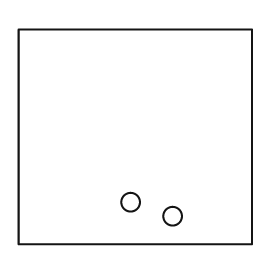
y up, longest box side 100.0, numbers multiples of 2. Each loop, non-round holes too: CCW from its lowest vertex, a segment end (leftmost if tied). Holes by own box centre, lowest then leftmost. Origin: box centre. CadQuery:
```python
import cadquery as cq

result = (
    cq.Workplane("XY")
    .moveTo(-50.0, -46.0)
    .lineTo(50.0, -46.0)
    .lineTo(50.0, 46.0)
    .lineTo(-50.0, 46.0)
    .close()
    .moveTo(16.0, -34.0)
    .circle(4.0)
    .moveTo(-2.0, -28.0)
    .circle(4.0)
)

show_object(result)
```